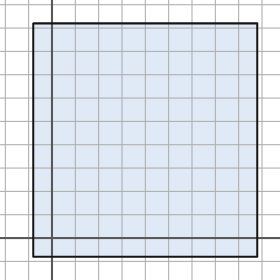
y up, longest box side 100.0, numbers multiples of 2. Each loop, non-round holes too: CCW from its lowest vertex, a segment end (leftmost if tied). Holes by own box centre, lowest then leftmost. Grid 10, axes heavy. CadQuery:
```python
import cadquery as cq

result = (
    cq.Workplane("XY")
    .moveTo(-8.0, -8.0)
    .lineTo(88.0, -8.0)
    .lineTo(88.0, 92.0)
    .lineTo(-8.0, 92.0)
    .close()
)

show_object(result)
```